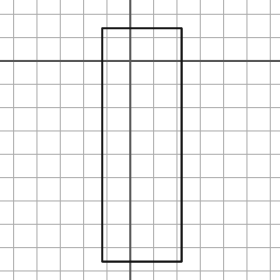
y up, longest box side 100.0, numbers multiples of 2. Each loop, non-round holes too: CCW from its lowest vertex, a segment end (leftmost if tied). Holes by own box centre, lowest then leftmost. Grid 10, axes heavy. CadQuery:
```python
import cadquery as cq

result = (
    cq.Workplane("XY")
    .moveTo(-12.0, -86.0)
    .lineTo(22.0, -86.0)
    .lineTo(22.0, 14.0)
    .lineTo(-12.0, 14.0)
    .close()
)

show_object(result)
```